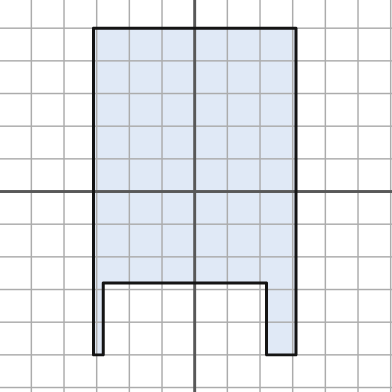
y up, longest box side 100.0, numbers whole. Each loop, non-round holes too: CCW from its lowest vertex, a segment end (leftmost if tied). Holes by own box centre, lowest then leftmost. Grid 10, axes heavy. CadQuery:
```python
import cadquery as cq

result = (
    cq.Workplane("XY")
    .moveTo(-31.0, -50.0)
    .lineTo(-28.0, -50.0)
    .lineTo(-28.0, -28.0)
    .lineTo(22.0, -28.0)
    .lineTo(22.0, -50.0)
    .lineTo(31.0, -50.0)
    .lineTo(31.0, 50.0)
    .lineTo(-31.0, 50.0)
    .close()
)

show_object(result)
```